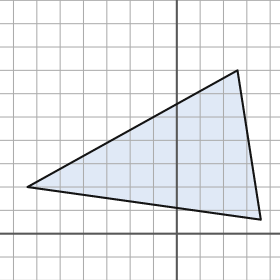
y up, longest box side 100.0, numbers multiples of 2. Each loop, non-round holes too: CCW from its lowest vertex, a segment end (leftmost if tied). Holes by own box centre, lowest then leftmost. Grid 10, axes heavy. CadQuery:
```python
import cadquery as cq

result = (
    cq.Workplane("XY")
    .moveTo(36.0, 6.0)
    .lineTo(26.0, 70.0)
    .lineTo(-64.0, 20.0)
    .close()
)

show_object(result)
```